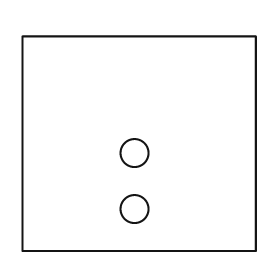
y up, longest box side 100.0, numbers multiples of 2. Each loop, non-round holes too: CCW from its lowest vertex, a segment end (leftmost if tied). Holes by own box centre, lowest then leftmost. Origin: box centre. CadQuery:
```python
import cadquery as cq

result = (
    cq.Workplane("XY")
    .moveTo(-50.0, -46.0)
    .lineTo(50.0, -46.0)
    .lineTo(50.0, 46.0)
    .lineTo(-50.0, 46.0)
    .close()
    .moveTo(-2.0, -28.0)
    .circle(6.0)
    .moveTo(-2.0, -4.0)
    .circle(6.0)
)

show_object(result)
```